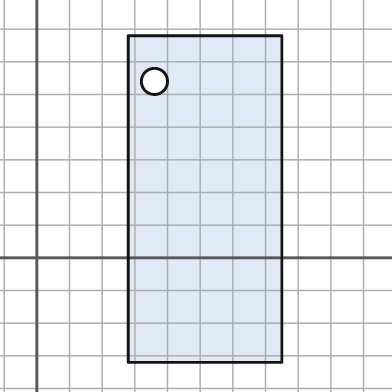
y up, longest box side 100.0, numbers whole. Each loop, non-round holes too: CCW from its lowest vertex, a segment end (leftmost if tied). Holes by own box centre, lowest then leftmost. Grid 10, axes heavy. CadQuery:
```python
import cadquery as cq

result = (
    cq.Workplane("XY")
    .moveTo(28.0, -32.0)
    .lineTo(75.0, -32.0)
    .lineTo(75.0, 68.0)
    .lineTo(28.0, 68.0)
    .close()
    .moveTo(36.0, 54.0)
    .circle(4.0)
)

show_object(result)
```